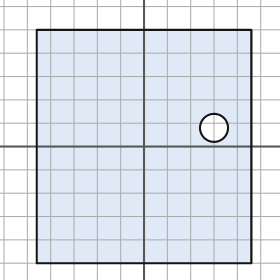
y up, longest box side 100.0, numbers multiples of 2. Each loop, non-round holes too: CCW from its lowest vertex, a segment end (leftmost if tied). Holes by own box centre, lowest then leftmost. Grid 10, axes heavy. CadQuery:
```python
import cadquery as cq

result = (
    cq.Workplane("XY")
    .moveTo(-46.0, -50.0)
    .lineTo(46.0, -50.0)
    .lineTo(46.0, 50.0)
    .lineTo(-46.0, 50.0)
    .close()
    .moveTo(30.0, 8.0)
    .circle(6.0)
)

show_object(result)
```